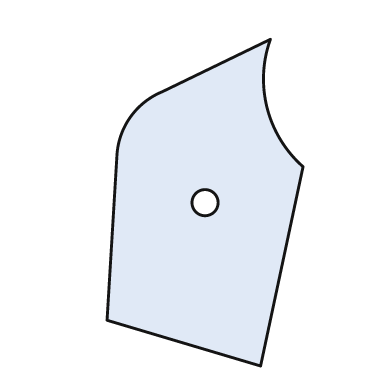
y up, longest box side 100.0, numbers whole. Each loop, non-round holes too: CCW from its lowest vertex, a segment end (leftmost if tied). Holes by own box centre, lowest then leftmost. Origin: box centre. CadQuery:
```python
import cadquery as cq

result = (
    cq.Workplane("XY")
    .moveTo(17.0, -50.0)
    .lineTo(30.0, 11.0)
    .threePointArc((19.0, 29.0), (20.0, 50.0))
    .lineTo(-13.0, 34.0)
    .threePointArc((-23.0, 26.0), (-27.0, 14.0))
    .lineTo(-30.0, -36.0)
    .close()
    .moveTo(0.0, 0.0)
    .circle(4.0)
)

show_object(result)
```